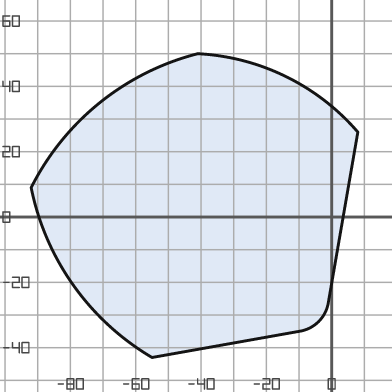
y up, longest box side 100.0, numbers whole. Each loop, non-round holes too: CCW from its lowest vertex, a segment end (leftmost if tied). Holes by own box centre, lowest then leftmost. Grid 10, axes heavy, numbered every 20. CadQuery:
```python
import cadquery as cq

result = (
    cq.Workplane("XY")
    .moveTo(-55.0, -43.0)
    .lineTo(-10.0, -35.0)
    .threePointArc((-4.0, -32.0), (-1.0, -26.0))
    .lineTo(8.0, 26.0)
    .threePointArc((-14.0, 43.0), (-41.0, 50.0))
    .threePointArc((-71.0, 35.0), (-92.0, 9.0))
    .threePointArc((-79.0, -21.0), (-55.0, -43.0))
    .close()
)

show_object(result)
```